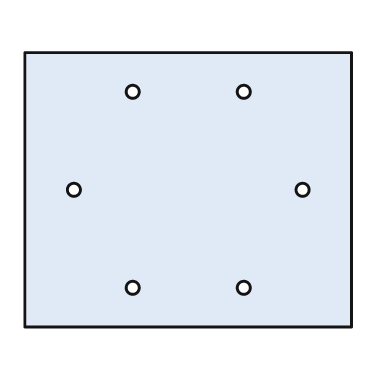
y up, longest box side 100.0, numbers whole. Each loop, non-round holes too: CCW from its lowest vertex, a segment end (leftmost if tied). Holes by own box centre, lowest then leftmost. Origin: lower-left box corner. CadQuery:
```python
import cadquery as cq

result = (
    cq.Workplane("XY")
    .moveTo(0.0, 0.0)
    .lineTo(100.0, 0.0)
    .lineTo(100.0, 84.0)
    .lineTo(0.0, 84.0)
    .close()
    .moveTo(33.0, 12.0)
    .circle(2.0)
    .moveTo(67.0, 12.0)
    .circle(2.0)
    .moveTo(15.0, 42.0)
    .circle(2.0)
    .moveTo(85.0, 42.0)
    .circle(2.0)
    .moveTo(33.0, 72.0)
    .circle(2.0)
    .moveTo(67.0, 72.0)
    .circle(2.0)
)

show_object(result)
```